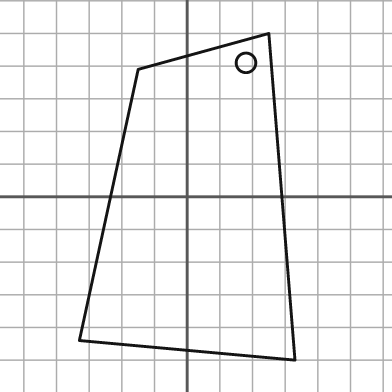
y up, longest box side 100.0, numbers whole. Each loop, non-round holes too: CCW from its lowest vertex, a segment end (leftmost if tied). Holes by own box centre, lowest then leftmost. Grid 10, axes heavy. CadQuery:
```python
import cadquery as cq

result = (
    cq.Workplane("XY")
    .moveTo(33.0, -50.0)
    .lineTo(25.0, 50.0)
    .lineTo(-15.0, 39.0)
    .lineTo(-33.0, -44.0)
    .close()
    .moveTo(18.0, 41.0)
    .circle(3.0)
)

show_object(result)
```